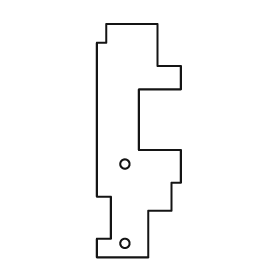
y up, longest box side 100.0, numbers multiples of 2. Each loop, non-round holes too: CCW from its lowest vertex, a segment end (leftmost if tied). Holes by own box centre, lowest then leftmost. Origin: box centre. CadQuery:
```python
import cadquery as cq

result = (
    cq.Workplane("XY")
    .moveTo(-18.0, -50.0)
    .lineTo(4.0, -50.0)
    .lineTo(4.0, -30.0)
    .lineTo(14.0, -30.0)
    .lineTo(14.0, -18.0)
    .lineTo(18.0, -18.0)
    .lineTo(18.0, -4.0)
    .lineTo(0.0, -4.0)
    .lineTo(0.0, 22.0)
    .lineTo(18.0, 22.0)
    .lineTo(18.0, 32.0)
    .lineTo(8.0, 32.0)
    .lineTo(8.0, 50.0)
    .lineTo(-14.0, 50.0)
    .lineTo(-14.0, 42.0)
    .lineTo(-18.0, 42.0)
    .lineTo(-18.0, -24.0)
    .lineTo(-12.0, -24.0)
    .lineTo(-12.0, -42.0)
    .lineTo(-18.0, -42.0)
    .close()
    .moveTo(-6.0, -44.0)
    .circle(2.0)
    .moveTo(-6.0, -10.0)
    .circle(2.0)
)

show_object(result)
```